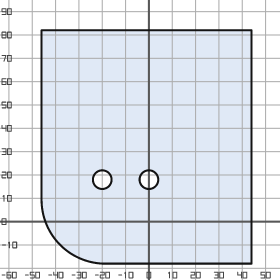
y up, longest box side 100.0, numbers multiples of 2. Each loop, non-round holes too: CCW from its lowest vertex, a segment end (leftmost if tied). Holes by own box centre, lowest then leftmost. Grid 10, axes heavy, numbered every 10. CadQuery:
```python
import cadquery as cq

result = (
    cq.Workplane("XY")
    .moveTo(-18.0, -18.0)
    .lineTo(44.0, -18.0)
    .lineTo(44.0, 82.0)
    .lineTo(-46.0, 82.0)
    .lineTo(-46.0, 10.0)
    .threePointArc((-38.0, -10.0), (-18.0, -18.0))
    .close()
    .moveTo(-20.0, 18.0)
    .circle(4.0)
    .moveTo(0.0, 18.0)
    .circle(4.0)
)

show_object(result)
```